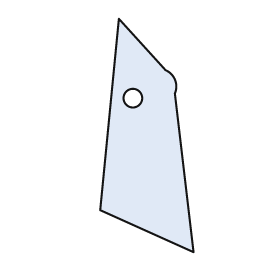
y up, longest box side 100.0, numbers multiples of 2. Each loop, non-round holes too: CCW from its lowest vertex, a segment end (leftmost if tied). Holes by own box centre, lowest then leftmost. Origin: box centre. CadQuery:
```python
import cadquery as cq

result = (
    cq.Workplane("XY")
    .moveTo(20.0, -50.0)
    .lineTo(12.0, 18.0)
    .threePointArc((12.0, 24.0), (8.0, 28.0))
    .lineTo(-12.0, 50.0)
    .lineTo(-20.0, -32.0)
    .close()
    .moveTo(-6.0, 16.0)
    .circle(4.0)
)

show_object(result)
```